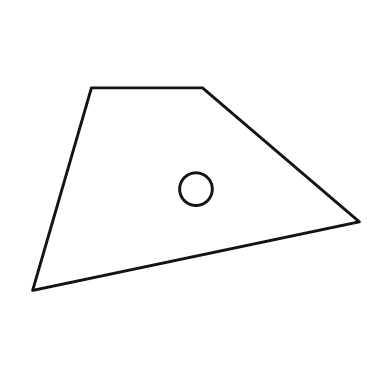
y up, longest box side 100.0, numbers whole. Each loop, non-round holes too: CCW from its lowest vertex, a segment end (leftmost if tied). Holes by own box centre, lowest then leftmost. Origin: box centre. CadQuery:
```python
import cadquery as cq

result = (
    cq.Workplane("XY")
    .moveTo(-50.0, -31.0)
    .lineTo(50.0, -10.0)
    .lineTo(2.0, 31.0)
    .lineTo(-32.0, 31.0)
    .close()
    .moveTo(0.0, 0.0)
    .circle(5.0)
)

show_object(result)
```